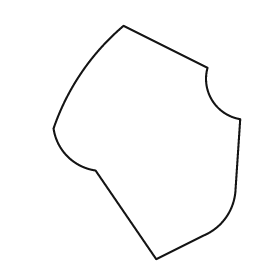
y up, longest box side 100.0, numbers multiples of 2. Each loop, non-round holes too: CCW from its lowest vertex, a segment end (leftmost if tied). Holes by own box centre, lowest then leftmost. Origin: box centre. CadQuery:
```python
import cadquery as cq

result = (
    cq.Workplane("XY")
    .moveTo(4.0, -50.0)
    .lineTo(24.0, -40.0)
    .threePointArc((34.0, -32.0), (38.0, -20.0))
    .lineTo(40.0, 10.0)
    .threePointArc((28.0, 18.0), (26.0, 32.0))
    .lineTo(-10.0, 50.0)
    .threePointArc((-28.0, 30.0), (-40.0, 6.0))
    .threePointArc((-34.0, -6.0), (-22.0, -12.0))
    .close()
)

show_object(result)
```